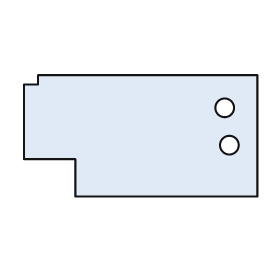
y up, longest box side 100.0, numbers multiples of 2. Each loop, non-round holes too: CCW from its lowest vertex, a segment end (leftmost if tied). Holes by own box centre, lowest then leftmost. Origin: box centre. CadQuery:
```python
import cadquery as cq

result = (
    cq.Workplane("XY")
    .moveTo(-28.0, -26.0)
    .lineTo(50.0, -26.0)
    .lineTo(50.0, 26.0)
    .lineTo(-44.0, 26.0)
    .lineTo(-44.0, 22.0)
    .lineTo(-50.0, 22.0)
    .lineTo(-50.0, -10.0)
    .lineTo(-28.0, -10.0)
    .close()
    .moveTo(38.0, -4.0)
    .circle(4.0)
    .moveTo(36.0, 12.0)
    .circle(4.0)
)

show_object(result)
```